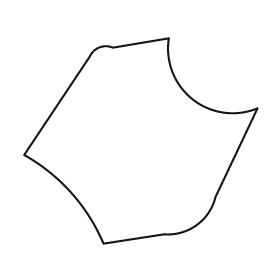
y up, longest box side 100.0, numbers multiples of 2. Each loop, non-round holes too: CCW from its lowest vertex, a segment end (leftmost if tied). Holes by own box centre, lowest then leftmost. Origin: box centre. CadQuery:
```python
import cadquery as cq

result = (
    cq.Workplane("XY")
    .moveTo(-16.0, -44.0)
    .lineTo(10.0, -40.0)
    .threePointArc((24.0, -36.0), (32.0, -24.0))
    .lineTo(50.0, 14.0)
    .threePointArc((22.0, 18.0), (12.0, 44.0))
    .lineTo(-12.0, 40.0)
    .threePointArc((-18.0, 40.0), (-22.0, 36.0))
    .lineTo(-50.0, -6.0)
    .threePointArc((-30.0, -22.0), (-16.0, -44.0))
    .close()
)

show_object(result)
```